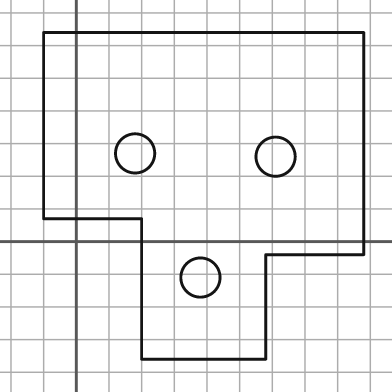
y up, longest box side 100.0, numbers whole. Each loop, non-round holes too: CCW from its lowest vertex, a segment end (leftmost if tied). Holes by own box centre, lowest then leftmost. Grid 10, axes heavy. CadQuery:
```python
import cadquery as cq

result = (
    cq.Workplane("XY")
    .moveTo(20.0, -36.0)
    .lineTo(58.0, -36.0)
    .lineTo(58.0, -4.0)
    .lineTo(88.0, -4.0)
    .lineTo(88.0, 64.0)
    .lineTo(-10.0, 64.0)
    .lineTo(-10.0, 7.0)
    .lineTo(20.0, 7.0)
    .close()
    .moveTo(38.0, -11.0)
    .circle(6.0)
    .moveTo(61.0, 26.0)
    .circle(6.0)
    .moveTo(18.0, 27.0)
    .circle(6.0)
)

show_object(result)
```